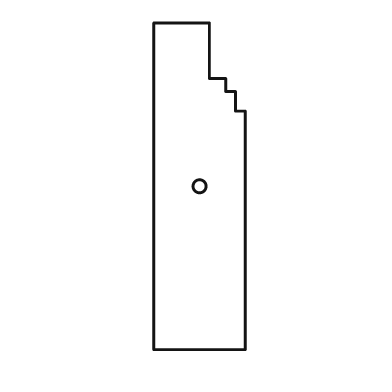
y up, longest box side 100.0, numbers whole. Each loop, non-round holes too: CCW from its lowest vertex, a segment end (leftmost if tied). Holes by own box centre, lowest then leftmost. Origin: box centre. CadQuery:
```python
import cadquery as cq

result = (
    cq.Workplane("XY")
    .moveTo(-14.0, -50.0)
    .lineTo(14.0, -50.0)
    .lineTo(14.0, 23.0)
    .lineTo(11.0, 23.0)
    .lineTo(11.0, 29.0)
    .lineTo(8.0, 29.0)
    .lineTo(8.0, 33.0)
    .lineTo(3.0, 33.0)
    .lineTo(3.0, 50.0)
    .lineTo(-14.0, 50.0)
    .close()
    .moveTo(0.0, 0.0)
    .circle(2.0)
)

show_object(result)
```